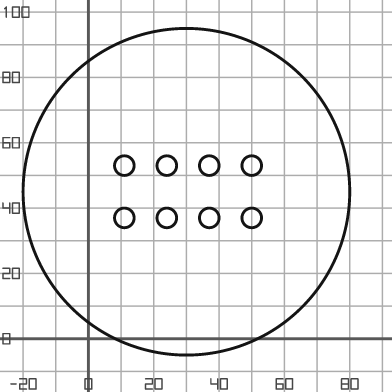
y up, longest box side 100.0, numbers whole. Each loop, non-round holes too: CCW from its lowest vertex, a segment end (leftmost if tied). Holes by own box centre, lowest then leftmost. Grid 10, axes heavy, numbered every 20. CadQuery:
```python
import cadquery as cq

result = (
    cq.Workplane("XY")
    .moveTo(30.0, 45.0)
    .circle(50.0)
    .moveTo(11.0, 37.0)
    .circle(3.0)
    .moveTo(24.0, 37.0)
    .circle(3.0)
    .moveTo(37.0, 37.0)
    .circle(3.0)
    .moveTo(50.0, 37.0)
    .circle(3.0)
    .moveTo(11.0, 53.0)
    .circle(3.0)
    .moveTo(24.0, 53.0)
    .circle(3.0)
    .moveTo(37.0, 53.0)
    .circle(3.0)
    .moveTo(50.0, 53.0)
    .circle(3.0)
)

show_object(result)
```